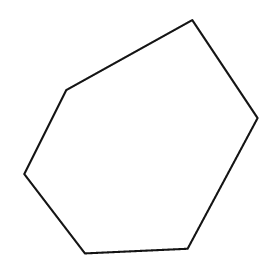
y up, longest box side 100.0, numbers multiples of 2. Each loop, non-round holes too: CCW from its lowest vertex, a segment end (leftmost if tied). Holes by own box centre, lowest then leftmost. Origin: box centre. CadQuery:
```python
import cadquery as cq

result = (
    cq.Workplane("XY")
    .moveTo(-24.0, -50.0)
    .lineTo(20.0, -48.0)
    .lineTo(50.0, 8.0)
    .lineTo(22.0, 50.0)
    .lineTo(-32.0, 20.0)
    .lineTo(-50.0, -16.0)
    .close()
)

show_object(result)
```